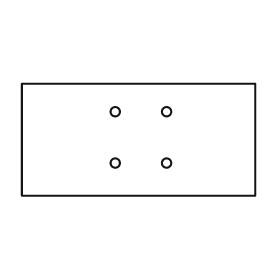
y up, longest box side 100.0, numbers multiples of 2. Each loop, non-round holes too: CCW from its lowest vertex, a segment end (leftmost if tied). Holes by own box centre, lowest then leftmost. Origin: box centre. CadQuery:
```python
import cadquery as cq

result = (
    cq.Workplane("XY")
    .moveTo(-50.0, -24.0)
    .lineTo(50.0, -24.0)
    .lineTo(50.0, 24.0)
    .lineTo(-50.0, 24.0)
    .close()
    .moveTo(-10.0, -10.0)
    .circle(2.0)
    .moveTo(12.0, -10.0)
    .circle(2.0)
    .moveTo(-10.0, 12.0)
    .circle(2.0)
    .moveTo(12.0, 12.0)
    .circle(2.0)
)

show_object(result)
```